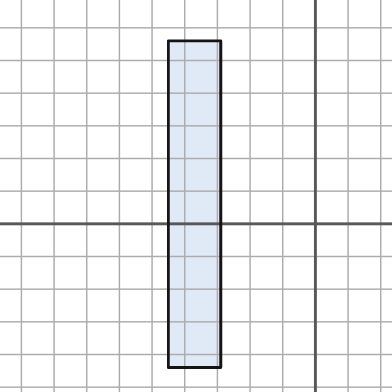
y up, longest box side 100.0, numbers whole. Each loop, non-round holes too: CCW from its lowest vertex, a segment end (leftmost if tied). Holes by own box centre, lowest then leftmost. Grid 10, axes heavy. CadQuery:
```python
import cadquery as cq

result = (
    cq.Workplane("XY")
    .moveTo(-45.0, -44.0)
    .lineTo(-29.0, -44.0)
    .lineTo(-29.0, 56.0)
    .lineTo(-45.0, 56.0)
    .close()
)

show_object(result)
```